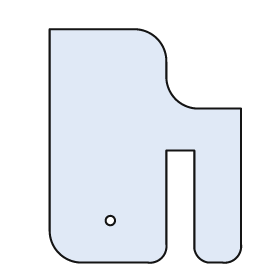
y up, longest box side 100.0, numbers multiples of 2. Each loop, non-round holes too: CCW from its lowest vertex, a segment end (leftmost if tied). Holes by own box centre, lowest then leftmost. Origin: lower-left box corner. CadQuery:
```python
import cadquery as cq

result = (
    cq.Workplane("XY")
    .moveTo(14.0, 0.0)
    .lineTo(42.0, 0.0)
    .threePointArc((48.0, 2.0), (50.0, 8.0))
    .lineTo(50.0, 48.0)
    .lineTo(62.0, 48.0)
    .lineTo(62.0, 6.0)
    .threePointArc((64.0, 2.0), (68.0, 0.0))
    .lineTo(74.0, 0.0)
    .threePointArc((80.0, 2.0), (82.0, 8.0))
    .lineTo(82.0, 66.0)
    .lineTo(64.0, 66.0)
    .threePointArc((54.0, 70.0), (50.0, 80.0))
    .lineTo(50.0, 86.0)
    .threePointArc((46.0, 96.0), (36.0, 100.0))
    .lineTo(0.0, 100.0)
    .lineTo(0.0, 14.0)
    .threePointArc((4.0, 4.0), (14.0, 0.0))
    .close()
    .moveTo(26.0, 18.0)
    .circle(2.0)
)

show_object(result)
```